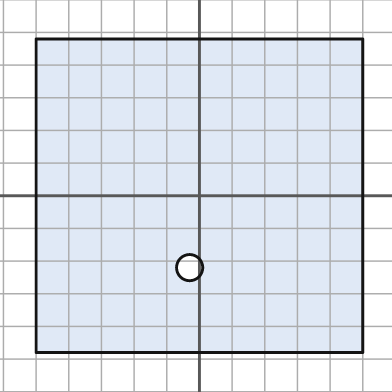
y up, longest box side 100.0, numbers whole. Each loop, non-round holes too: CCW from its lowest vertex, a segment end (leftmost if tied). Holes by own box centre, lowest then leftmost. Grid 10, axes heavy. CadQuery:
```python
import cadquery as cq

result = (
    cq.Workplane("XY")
    .moveTo(-50.0, -48.0)
    .lineTo(50.0, -48.0)
    .lineTo(50.0, 48.0)
    .lineTo(-50.0, 48.0)
    .close()
    .moveTo(-3.0, -22.0)
    .circle(4.0)
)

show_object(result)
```